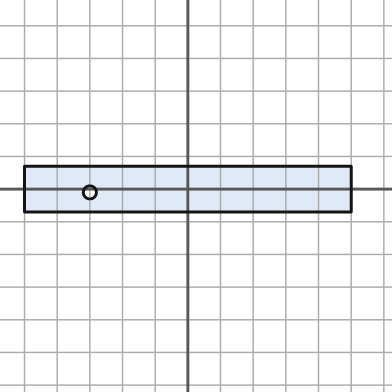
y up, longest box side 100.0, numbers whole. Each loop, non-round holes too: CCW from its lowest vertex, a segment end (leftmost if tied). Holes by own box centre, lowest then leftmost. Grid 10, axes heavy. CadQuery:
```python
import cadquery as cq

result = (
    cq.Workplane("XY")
    .moveTo(-50.0, -7.0)
    .lineTo(50.0, -7.0)
    .lineTo(50.0, 7.0)
    .lineTo(-50.0, 7.0)
    .close()
    .moveTo(-30.0, -1.0)
    .circle(2.0)
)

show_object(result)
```